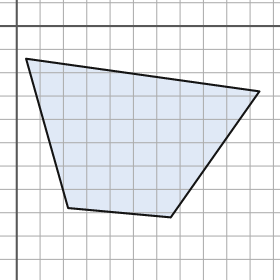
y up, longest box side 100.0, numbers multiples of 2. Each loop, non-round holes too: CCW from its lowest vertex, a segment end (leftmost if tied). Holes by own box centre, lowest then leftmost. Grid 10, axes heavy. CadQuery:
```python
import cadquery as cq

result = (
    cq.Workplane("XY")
    .moveTo(66.0, -82.0)
    .lineTo(104.0, -28.0)
    .lineTo(4.0, -14.0)
    .lineTo(22.0, -78.0)
    .close()
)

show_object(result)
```